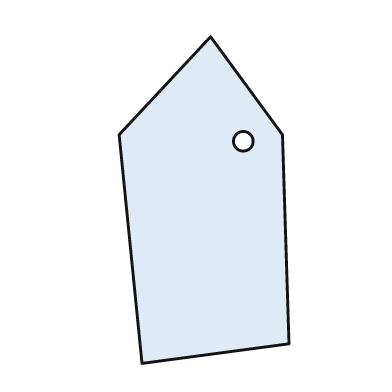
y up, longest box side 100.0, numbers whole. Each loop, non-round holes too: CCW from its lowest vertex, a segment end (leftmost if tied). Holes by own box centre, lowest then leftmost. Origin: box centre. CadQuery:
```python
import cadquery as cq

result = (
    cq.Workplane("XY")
    .moveTo(-19.0, -50.0)
    .lineTo(26.0, -44.0)
    .lineTo(24.0, 20.0)
    .lineTo(2.0, 50.0)
    .lineTo(-26.0, 20.0)
    .close()
    .moveTo(12.0, 18.0)
    .circle(3.0)
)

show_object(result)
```